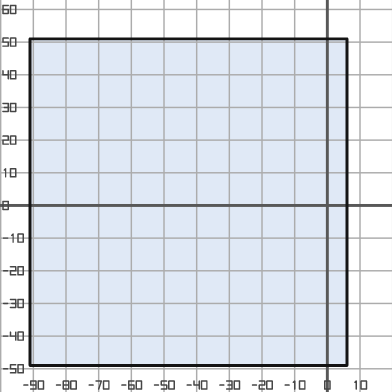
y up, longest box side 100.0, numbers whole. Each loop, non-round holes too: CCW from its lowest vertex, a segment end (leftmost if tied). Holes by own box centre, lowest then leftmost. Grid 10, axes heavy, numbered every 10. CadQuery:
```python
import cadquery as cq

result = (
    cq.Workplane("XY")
    .moveTo(-91.0, -49.0)
    .lineTo(6.0, -49.0)
    .lineTo(6.0, 51.0)
    .lineTo(-91.0, 51.0)
    .close()
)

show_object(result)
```